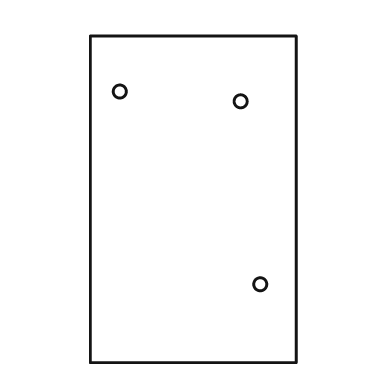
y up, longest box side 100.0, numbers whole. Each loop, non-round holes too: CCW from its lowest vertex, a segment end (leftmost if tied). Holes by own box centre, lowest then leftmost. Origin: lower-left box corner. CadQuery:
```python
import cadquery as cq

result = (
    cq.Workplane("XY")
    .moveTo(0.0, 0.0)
    .lineTo(63.0, 0.0)
    .lineTo(63.0, 100.0)
    .lineTo(0.0, 100.0)
    .close()
    .moveTo(52.0, 24.0)
    .circle(2.0)
    .moveTo(46.0, 80.0)
    .circle(2.0)
    .moveTo(9.0, 83.0)
    .circle(2.0)
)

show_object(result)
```